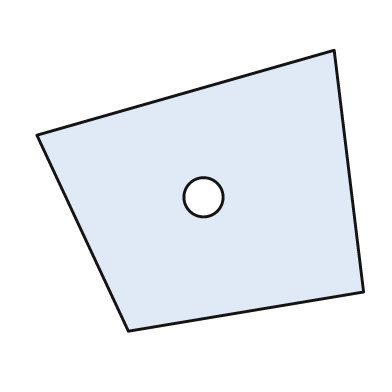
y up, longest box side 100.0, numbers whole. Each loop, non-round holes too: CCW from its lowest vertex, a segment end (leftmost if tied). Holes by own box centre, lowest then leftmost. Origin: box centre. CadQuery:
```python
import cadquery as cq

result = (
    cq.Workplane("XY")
    .moveTo(-22.0, -43.0)
    .lineTo(50.0, -31.0)
    .lineTo(41.0, 43.0)
    .lineTo(-50.0, 17.0)
    .close()
    .moveTo(1.0, -2.0)
    .circle(6.0)
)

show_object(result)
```